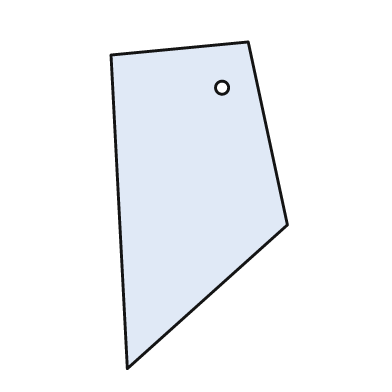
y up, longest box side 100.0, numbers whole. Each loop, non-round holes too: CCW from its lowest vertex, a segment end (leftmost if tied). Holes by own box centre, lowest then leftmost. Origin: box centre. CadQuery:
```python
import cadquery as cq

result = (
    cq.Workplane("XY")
    .moveTo(-22.0, -50.0)
    .lineTo(27.0, -6.0)
    .lineTo(15.0, 50.0)
    .lineTo(-27.0, 46.0)
    .close()
    .moveTo(7.0, 36.0)
    .circle(2.0)
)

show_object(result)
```